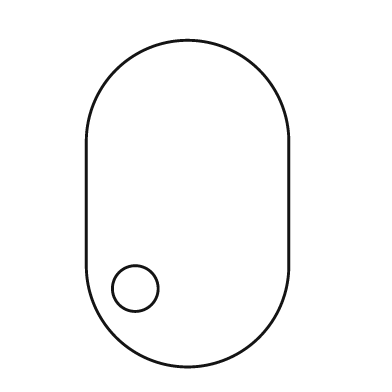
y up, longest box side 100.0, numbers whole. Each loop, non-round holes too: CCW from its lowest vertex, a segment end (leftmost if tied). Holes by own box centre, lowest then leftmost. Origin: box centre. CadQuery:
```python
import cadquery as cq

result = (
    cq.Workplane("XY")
    .moveTo(-31.0, -19.0)
    .threePointArc((0.0, -50.0), (31.0, -19.0))
    .lineTo(31.0, 19.0)
    .threePointArc((0.0, 50.0), (-31.0, 19.0))
    .close()
    .moveTo(-16.0, -26.0)
    .circle(7.0)
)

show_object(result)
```